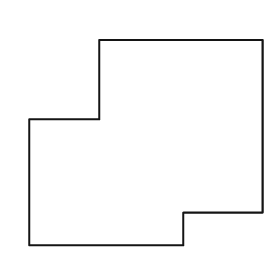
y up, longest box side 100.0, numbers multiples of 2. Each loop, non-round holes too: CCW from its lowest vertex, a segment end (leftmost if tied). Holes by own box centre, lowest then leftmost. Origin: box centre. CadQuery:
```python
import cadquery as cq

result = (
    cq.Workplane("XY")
    .moveTo(-50.0, -44.0)
    .lineTo(16.0, -44.0)
    .lineTo(16.0, -30.0)
    .lineTo(50.0, -30.0)
    .lineTo(50.0, 44.0)
    .lineTo(-20.0, 44.0)
    .lineTo(-20.0, 10.0)
    .lineTo(-50.0, 10.0)
    .close()
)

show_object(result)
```